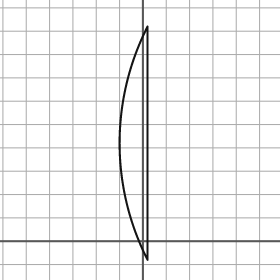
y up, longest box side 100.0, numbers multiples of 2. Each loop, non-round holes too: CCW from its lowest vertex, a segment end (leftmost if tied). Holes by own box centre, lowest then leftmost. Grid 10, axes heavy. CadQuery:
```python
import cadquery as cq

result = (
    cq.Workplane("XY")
    .moveTo(2.0, -8.0)
    .lineTo(2.0, 92.0)
    .threePointArc((-10.0, 42.0), (2.0, -8.0))
    .close()
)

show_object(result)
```